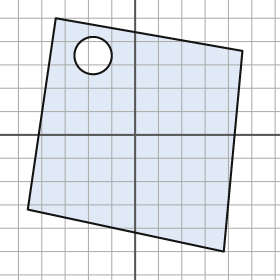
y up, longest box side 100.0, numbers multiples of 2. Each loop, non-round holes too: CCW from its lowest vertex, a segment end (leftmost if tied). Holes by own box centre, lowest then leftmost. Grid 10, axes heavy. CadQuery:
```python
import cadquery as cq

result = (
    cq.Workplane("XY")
    .moveTo(38.0, -50.0)
    .lineTo(46.0, 36.0)
    .lineTo(-34.0, 50.0)
    .lineTo(-46.0, -32.0)
    .close()
    .moveTo(-18.0, 34.0)
    .circle(8.0)
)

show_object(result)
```